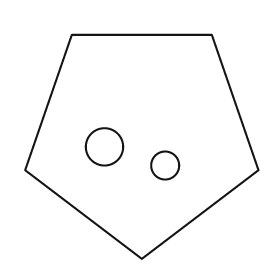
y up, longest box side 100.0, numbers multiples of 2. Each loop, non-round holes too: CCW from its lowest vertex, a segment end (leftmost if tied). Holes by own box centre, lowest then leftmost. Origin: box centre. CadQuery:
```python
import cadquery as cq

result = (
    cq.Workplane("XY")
    .moveTo(0.0, -48.0)
    .lineTo(50.0, -10.0)
    .lineTo(30.0, 48.0)
    .lineTo(-30.0, 48.0)
    .lineTo(-50.0, -10.0)
    .close()
    .moveTo(10.0, -8.0)
    .circle(6.0)
    .moveTo(-16.0, 0.0)
    .circle(8.0)
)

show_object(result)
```